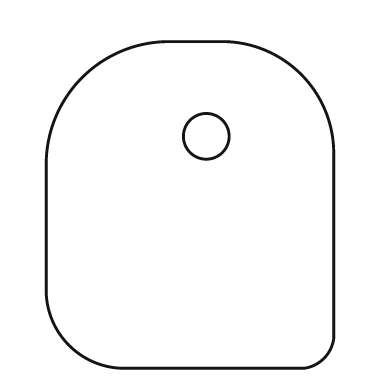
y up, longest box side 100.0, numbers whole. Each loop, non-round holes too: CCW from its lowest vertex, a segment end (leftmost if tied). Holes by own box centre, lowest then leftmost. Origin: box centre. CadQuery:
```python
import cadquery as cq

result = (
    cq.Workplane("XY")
    .moveTo(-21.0, -50.0)
    .lineTo(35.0, -50.0)
    .threePointArc((41.0, -47.0), (44.0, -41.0))
    .lineTo(44.0, 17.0)
    .threePointArc((34.0, 40.0), (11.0, 50.0))
    .lineTo(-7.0, 50.0)
    .threePointArc((-33.0, 39.0), (-44.0, 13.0))
    .lineTo(-44.0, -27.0)
    .threePointArc((-37.0, -43.0), (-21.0, -50.0))
    .close()
    .moveTo(5.0, 21.0)
    .circle(7.0)
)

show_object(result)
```